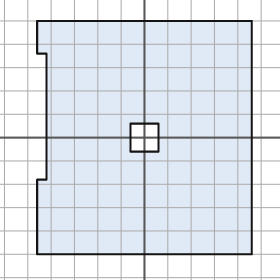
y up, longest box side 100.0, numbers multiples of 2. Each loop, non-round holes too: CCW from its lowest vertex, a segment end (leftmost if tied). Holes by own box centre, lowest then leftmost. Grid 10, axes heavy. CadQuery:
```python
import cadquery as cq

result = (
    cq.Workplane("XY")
    .moveTo(-46.0, -50.0)
    .lineTo(46.0, -50.0)
    .lineTo(46.0, 50.0)
    .lineTo(-46.0, 50.0)
    .lineTo(-46.0, 36.0)
    .lineTo(-42.0, 36.0)
    .lineTo(-42.0, -18.0)
    .lineTo(-46.0, -18.0)
    .close()
    .moveTo(-6.0, -6.0)
    .lineTo(6.0, -6.0)
    .lineTo(6.0, 6.0)
    .lineTo(-6.0, 6.0)
    .close()
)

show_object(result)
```